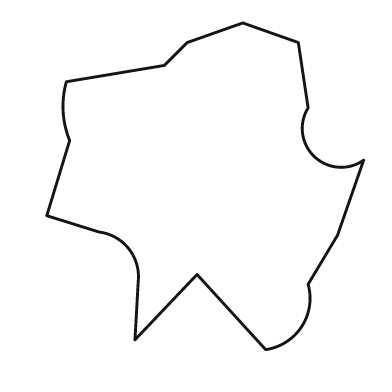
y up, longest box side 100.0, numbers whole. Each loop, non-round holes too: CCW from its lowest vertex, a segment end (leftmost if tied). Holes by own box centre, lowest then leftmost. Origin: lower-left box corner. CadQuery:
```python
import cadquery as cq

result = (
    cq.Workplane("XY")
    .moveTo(67.0, 0.0)
    .threePointArc((78.0, 7.0), (80.0, 20.0))
    .lineTo(89.0, 35.0)
    .lineTo(97.0, 58.0)
    .threePointArc((82.0, 59.0), (80.0, 74.0))
    .lineTo(77.0, 94.0)
    .lineTo(60.0, 100.0)
    .lineTo(43.0, 94.0)
    .lineTo(36.0, 87.0)
    .lineTo(6.0, 82.0)
    .threePointArc((5.0, 73.0), (7.0, 64.0))
    .lineTo(0.0, 41.0)
    .lineTo(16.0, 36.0)
    .threePointArc((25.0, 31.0), (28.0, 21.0))
    .lineTo(27.0, 3.0)
    .lineTo(46.0, 23.0)
    .close()
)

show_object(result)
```